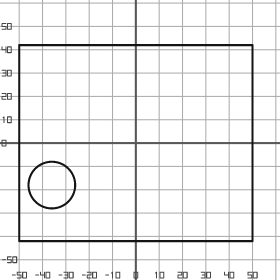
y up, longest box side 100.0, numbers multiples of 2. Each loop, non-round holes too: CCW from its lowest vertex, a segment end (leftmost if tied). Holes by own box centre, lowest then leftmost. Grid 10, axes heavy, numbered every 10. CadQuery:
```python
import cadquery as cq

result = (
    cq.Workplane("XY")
    .moveTo(-50.0, -42.0)
    .lineTo(50.0, -42.0)
    .lineTo(50.0, 42.0)
    .lineTo(-50.0, 42.0)
    .close()
    .moveTo(-36.0, -18.0)
    .circle(10.0)
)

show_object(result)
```